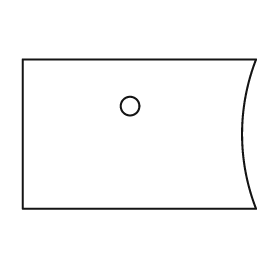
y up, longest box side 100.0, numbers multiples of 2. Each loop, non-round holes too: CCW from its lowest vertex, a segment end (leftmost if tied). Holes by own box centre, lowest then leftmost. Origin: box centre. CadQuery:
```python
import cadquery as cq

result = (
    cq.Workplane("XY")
    .moveTo(-50.0, -32.0)
    .lineTo(50.0, -32.0)
    .threePointArc((44.0, 0.0), (50.0, 32.0))
    .lineTo(-50.0, 32.0)
    .close()
    .moveTo(-4.0, 12.0)
    .circle(4.0)
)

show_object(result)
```